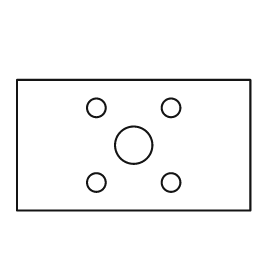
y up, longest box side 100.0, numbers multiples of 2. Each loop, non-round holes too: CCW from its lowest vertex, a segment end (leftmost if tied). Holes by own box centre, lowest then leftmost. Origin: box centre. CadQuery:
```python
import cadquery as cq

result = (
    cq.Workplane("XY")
    .moveTo(-50.0, -28.0)
    .lineTo(50.0, -28.0)
    .lineTo(50.0, 28.0)
    .lineTo(-50.0, 28.0)
    .close()
    .moveTo(-16.0, -16.0)
    .circle(4.0)
    .moveTo(16.0, -16.0)
    .circle(4.0)
    .moveTo(0.0, 0.0)
    .circle(8.0)
    .moveTo(-16.0, 16.0)
    .circle(4.0)
    .moveTo(16.0, 16.0)
    .circle(4.0)
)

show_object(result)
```